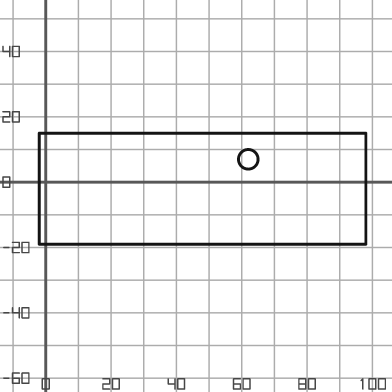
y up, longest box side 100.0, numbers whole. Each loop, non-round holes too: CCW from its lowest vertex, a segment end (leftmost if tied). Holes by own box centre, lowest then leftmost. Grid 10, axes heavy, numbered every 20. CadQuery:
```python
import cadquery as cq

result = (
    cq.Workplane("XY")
    .moveTo(-2.0, -19.0)
    .lineTo(98.0, -19.0)
    .lineTo(98.0, 15.0)
    .lineTo(-2.0, 15.0)
    .close()
    .moveTo(62.0, 7.0)
    .circle(3.0)
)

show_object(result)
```